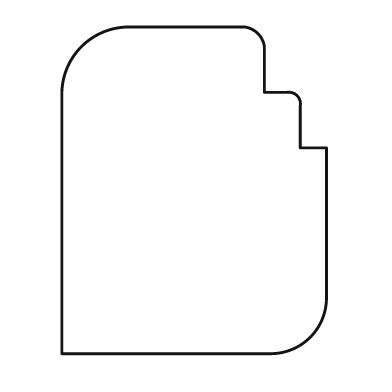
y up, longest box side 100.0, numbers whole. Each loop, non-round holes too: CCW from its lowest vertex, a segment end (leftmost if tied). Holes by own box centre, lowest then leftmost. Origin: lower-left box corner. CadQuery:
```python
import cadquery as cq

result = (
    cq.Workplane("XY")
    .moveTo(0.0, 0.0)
    .lineTo(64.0, 0.0)
    .threePointArc((76.0, 5.0), (81.0, 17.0))
    .lineTo(81.0, 63.0)
    .lineTo(73.0, 63.0)
    .lineTo(73.0, 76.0)
    .threePointArc((72.0, 79.0), (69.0, 80.0))
    .lineTo(62.0, 80.0)
    .lineTo(62.0, 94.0)
    .threePointArc((60.0, 98.0), (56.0, 100.0))
    .lineTo(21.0, 100.0)
    .threePointArc((6.0, 94.0), (0.0, 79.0))
    .close()
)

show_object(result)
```